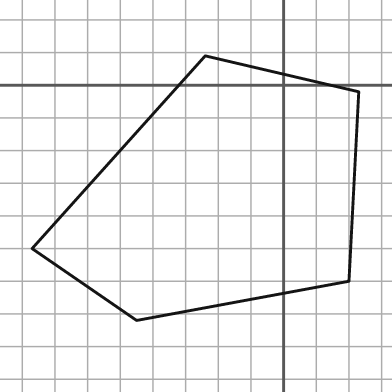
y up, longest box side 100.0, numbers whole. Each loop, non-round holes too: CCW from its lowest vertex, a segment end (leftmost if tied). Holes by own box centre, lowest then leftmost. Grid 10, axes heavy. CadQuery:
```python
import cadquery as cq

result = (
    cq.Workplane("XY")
    .moveTo(-45.0, -72.0)
    .lineTo(20.0, -60.0)
    .lineTo(23.0, -2.0)
    .lineTo(-24.0, 9.0)
    .lineTo(-77.0, -50.0)
    .close()
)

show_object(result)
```